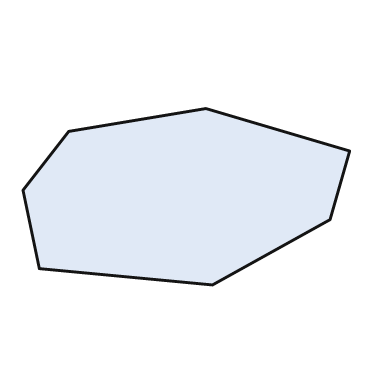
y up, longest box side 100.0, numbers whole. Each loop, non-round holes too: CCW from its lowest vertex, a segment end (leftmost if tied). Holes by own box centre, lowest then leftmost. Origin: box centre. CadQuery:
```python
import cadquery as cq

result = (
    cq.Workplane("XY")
    .moveTo(8.0, -27.0)
    .lineTo(44.0, -7.0)
    .lineTo(50.0, 14.0)
    .lineTo(6.0, 27.0)
    .lineTo(-36.0, 20.0)
    .lineTo(-50.0, 2.0)
    .lineTo(-45.0, -22.0)
    .close()
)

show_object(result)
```